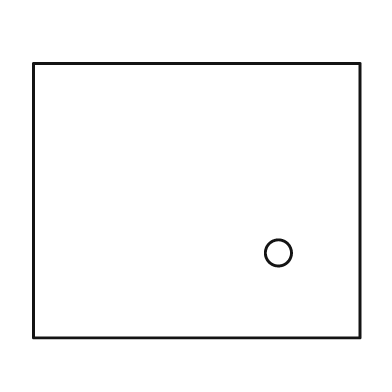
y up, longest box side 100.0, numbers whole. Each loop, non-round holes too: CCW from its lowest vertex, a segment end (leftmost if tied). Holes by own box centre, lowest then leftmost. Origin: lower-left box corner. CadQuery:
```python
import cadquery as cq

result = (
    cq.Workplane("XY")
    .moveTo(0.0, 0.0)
    .lineTo(100.0, 0.0)
    .lineTo(100.0, 84.0)
    .lineTo(0.0, 84.0)
    .close()
    .moveTo(75.0, 26.0)
    .circle(4.0)
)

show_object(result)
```